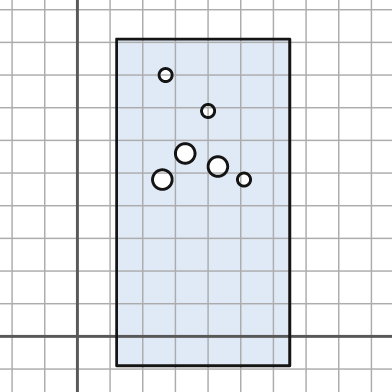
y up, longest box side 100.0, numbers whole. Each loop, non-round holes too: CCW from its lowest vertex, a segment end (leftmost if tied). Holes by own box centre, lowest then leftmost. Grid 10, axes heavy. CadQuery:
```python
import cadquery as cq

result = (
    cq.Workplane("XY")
    .moveTo(12.0, -9.0)
    .lineTo(65.0, -9.0)
    .lineTo(65.0, 91.0)
    .lineTo(12.0, 91.0)
    .close()
    .moveTo(26.0, 48.0)
    .circle(3.0)
    .moveTo(51.0, 48.0)
    .circle(2.0)
    .moveTo(43.0, 52.0)
    .circle(3.0)
    .moveTo(33.0, 56.0)
    .circle(3.0)
    .moveTo(40.0, 69.0)
    .circle(2.0)
    .moveTo(27.0, 80.0)
    .circle(2.0)
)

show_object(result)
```